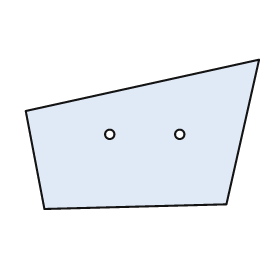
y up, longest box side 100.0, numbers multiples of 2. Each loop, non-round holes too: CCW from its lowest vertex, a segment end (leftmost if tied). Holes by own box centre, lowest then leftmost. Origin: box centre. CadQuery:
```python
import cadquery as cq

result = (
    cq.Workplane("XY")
    .moveTo(-42.0, -32.0)
    .lineTo(36.0, -30.0)
    .lineTo(50.0, 32.0)
    .lineTo(-50.0, 10.0)
    .close()
    .moveTo(-14.0, 0.0)
    .circle(2.0)
    .moveTo(16.0, 0.0)
    .circle(2.0)
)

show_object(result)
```